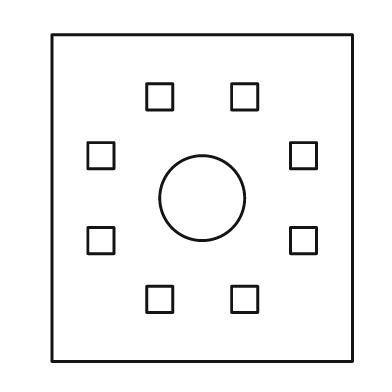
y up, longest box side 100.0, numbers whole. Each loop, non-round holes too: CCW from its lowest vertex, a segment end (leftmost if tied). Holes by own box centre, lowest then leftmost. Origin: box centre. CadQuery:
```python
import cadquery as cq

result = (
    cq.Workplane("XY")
    .moveTo(-46.0, -50.0)
    .lineTo(46.0, -50.0)
    .lineTo(46.0, 50.0)
    .lineTo(-46.0, 50.0)
    .close()
    .moveTo(-17.0, -35.0)
    .lineTo(-9.0, -35.0)
    .lineTo(-9.0, -27.0)
    .lineTo(-17.0, -27.0)
    .close()
    .moveTo(9.0, -35.0)
    .lineTo(17.0, -35.0)
    .lineTo(17.0, -27.0)
    .lineTo(9.0, -27.0)
    .close()
    .moveTo(-35.0, -17.0)
    .lineTo(-27.0, -17.0)
    .lineTo(-27.0, -9.0)
    .lineTo(-35.0, -9.0)
    .close()
    .moveTo(27.0, -17.0)
    .lineTo(35.0, -17.0)
    .lineTo(35.0, -9.0)
    .lineTo(27.0, -9.0)
    .close()
    .moveTo(0.0, 0.0)
    .circle(13.0)
    .moveTo(-35.0, 9.0)
    .lineTo(-27.0, 9.0)
    .lineTo(-27.0, 17.0)
    .lineTo(-35.0, 17.0)
    .close()
    .moveTo(27.0, 9.0)
    .lineTo(35.0, 9.0)
    .lineTo(35.0, 17.0)
    .lineTo(27.0, 17.0)
    .close()
    .moveTo(-17.0, 27.0)
    .lineTo(-9.0, 27.0)
    .lineTo(-9.0, 35.0)
    .lineTo(-17.0, 35.0)
    .close()
    .moveTo(9.0, 27.0)
    .lineTo(17.0, 27.0)
    .lineTo(17.0, 35.0)
    .lineTo(9.0, 35.0)
    .close()
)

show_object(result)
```